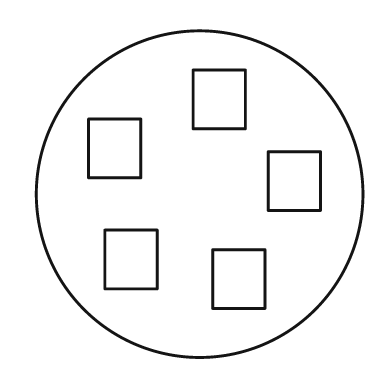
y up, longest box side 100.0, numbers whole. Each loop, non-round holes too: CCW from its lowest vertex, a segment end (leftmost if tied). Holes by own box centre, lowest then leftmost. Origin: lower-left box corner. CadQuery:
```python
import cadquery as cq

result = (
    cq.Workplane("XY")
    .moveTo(50.0, 50.0)
    .circle(50.0)
    .moveTo(54.0, 15.0)
    .lineTo(70.0, 15.0)
    .lineTo(70.0, 33.0)
    .lineTo(54.0, 33.0)
    .close()
    .moveTo(21.0, 21.0)
    .lineTo(37.0, 21.0)
    .lineTo(37.0, 39.0)
    .lineTo(21.0, 39.0)
    .close()
    .moveTo(71.0, 45.0)
    .lineTo(87.0, 45.0)
    .lineTo(87.0, 63.0)
    .lineTo(71.0, 63.0)
    .close()
    .moveTo(16.0, 55.0)
    .lineTo(32.0, 55.0)
    .lineTo(32.0, 73.0)
    .lineTo(16.0, 73.0)
    .close()
    .moveTo(48.0, 70.0)
    .lineTo(64.0, 70.0)
    .lineTo(64.0, 88.0)
    .lineTo(48.0, 88.0)
    .close()
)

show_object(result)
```